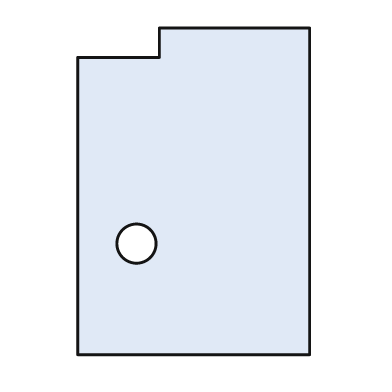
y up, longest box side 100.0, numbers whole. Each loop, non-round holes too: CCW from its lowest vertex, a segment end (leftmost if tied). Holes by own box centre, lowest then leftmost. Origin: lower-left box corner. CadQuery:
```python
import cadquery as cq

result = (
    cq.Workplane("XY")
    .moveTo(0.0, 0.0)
    .lineTo(71.0, 0.0)
    .lineTo(71.0, 100.0)
    .lineTo(25.0, 100.0)
    .lineTo(25.0, 91.0)
    .lineTo(0.0, 91.0)
    .close()
    .moveTo(18.0, 34.0)
    .circle(6.0)
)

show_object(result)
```